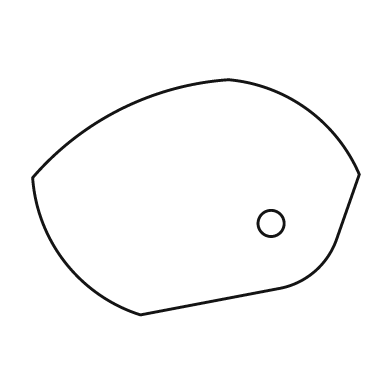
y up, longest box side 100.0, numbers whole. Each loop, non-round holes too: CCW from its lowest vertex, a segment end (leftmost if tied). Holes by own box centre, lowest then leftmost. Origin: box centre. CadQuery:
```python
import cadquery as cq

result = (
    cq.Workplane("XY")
    .moveTo(-17.0, -36.0)
    .lineTo(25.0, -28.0)
    .threePointArc((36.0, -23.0), (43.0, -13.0))
    .lineTo(50.0, 7.0)
    .threePointArc((34.0, 27.0), (10.0, 36.0))
    .threePointArc((-23.0, 27.0), (-50.0, 6.0))
    .threePointArc((-40.0, -20.0), (-17.0, -36.0))
    .close()
    .moveTo(23.0, -8.0)
    .circle(4.0)
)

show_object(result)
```